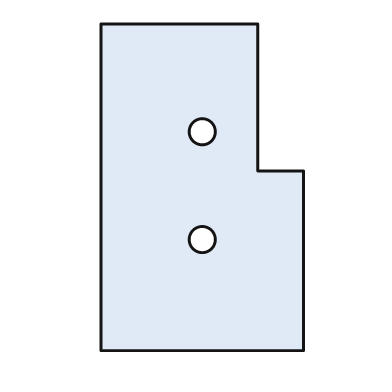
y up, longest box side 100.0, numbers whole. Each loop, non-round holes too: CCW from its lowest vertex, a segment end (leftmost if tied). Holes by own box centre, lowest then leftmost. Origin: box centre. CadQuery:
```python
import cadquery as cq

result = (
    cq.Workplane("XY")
    .moveTo(-31.0, -50.0)
    .lineTo(31.0, -50.0)
    .lineTo(31.0, 5.0)
    .lineTo(17.0, 5.0)
    .lineTo(17.0, 50.0)
    .lineTo(-31.0, 50.0)
    .close()
    .moveTo(0.0, -16.0)
    .circle(4.0)
    .moveTo(0.0, 17.0)
    .circle(4.0)
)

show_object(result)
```